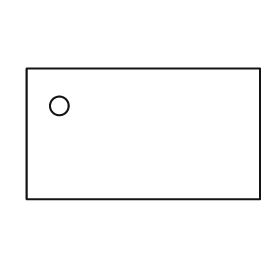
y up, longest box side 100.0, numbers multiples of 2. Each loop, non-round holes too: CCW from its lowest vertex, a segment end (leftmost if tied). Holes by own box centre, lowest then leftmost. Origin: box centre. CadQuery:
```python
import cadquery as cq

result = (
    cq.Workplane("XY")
    .moveTo(-50.0, -28.0)
    .lineTo(50.0, -28.0)
    .lineTo(50.0, 28.0)
    .lineTo(-50.0, 28.0)
    .close()
    .moveTo(-36.0, 12.0)
    .circle(4.0)
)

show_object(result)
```